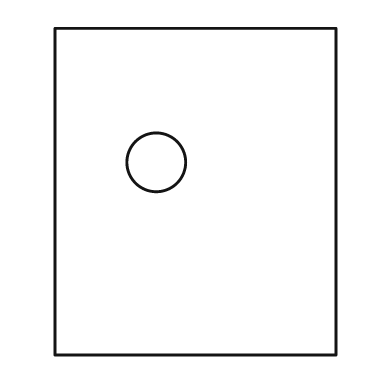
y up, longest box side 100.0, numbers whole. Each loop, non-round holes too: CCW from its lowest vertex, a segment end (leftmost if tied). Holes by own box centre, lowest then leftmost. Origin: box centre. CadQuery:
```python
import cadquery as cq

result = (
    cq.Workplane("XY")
    .moveTo(-43.0, -50.0)
    .lineTo(43.0, -50.0)
    .lineTo(43.0, 50.0)
    .lineTo(-43.0, 50.0)
    .close()
    .moveTo(-12.0, 9.0)
    .circle(9.0)
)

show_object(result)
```